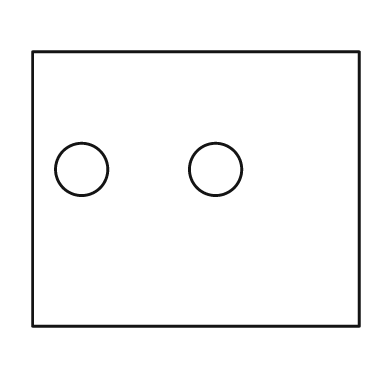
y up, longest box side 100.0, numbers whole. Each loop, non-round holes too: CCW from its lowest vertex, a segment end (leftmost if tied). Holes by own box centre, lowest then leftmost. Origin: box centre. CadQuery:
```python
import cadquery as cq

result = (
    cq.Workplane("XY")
    .moveTo(-50.0, -42.0)
    .lineTo(50.0, -42.0)
    .lineTo(50.0, 42.0)
    .lineTo(-50.0, 42.0)
    .close()
    .moveTo(-35.0, 6.0)
    .circle(8.0)
    .moveTo(6.0, 6.0)
    .circle(8.0)
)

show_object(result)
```